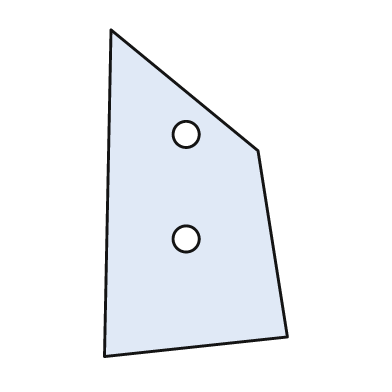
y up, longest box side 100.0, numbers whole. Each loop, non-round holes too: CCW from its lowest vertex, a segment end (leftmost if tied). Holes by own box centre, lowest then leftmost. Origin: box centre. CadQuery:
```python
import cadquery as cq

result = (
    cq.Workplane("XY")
    .moveTo(-28.0, -50.0)
    .lineTo(28.0, -44.0)
    .lineTo(19.0, 13.0)
    .lineTo(-26.0, 50.0)
    .close()
    .moveTo(-3.0, -14.0)
    .circle(4.0)
    .moveTo(-3.0, 18.0)
    .circle(4.0)
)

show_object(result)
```